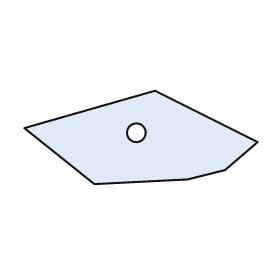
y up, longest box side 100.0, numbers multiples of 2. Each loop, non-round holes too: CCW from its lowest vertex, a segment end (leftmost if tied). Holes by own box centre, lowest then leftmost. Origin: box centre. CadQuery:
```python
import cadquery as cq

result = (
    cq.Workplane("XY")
    .moveTo(-20.0, -20.0)
    .lineTo(20.0, -18.0)
    .lineTo(36.0, -14.0)
    .lineTo(50.0, -2.0)
    .lineTo(6.0, 20.0)
    .lineTo(-50.0, 4.0)
    .close()
    .moveTo(-2.0, 2.0)
    .circle(4.0)
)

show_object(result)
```